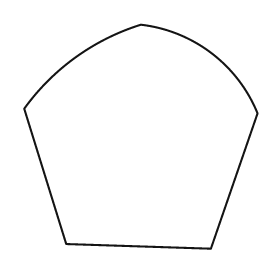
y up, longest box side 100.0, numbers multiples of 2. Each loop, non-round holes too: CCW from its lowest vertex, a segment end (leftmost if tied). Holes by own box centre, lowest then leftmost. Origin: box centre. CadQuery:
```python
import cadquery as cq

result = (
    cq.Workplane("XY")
    .moveTo(30.0, -48.0)
    .lineTo(50.0, 10.0)
    .threePointArc((30.0, 36.0), (0.0, 48.0))
    .threePointArc((-28.0, 34.0), (-50.0, 12.0))
    .lineTo(-32.0, -46.0)
    .close()
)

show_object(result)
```